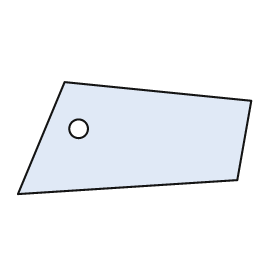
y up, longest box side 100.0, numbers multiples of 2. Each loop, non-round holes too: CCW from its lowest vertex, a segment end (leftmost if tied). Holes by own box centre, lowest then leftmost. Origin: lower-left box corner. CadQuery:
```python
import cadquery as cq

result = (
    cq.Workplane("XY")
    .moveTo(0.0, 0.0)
    .lineTo(94.0, 6.0)
    .lineTo(100.0, 40.0)
    .lineTo(20.0, 48.0)
    .close()
    .moveTo(26.0, 28.0)
    .circle(4.0)
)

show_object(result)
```